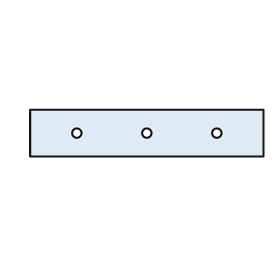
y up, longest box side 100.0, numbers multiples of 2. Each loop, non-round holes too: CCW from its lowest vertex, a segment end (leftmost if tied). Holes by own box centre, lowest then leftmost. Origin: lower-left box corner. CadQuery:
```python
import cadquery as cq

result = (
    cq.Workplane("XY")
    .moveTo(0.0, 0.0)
    .lineTo(100.0, 0.0)
    .lineTo(100.0, 20.0)
    .lineTo(0.0, 20.0)
    .close()
    .moveTo(20.0, 10.0)
    .circle(2.0)
    .moveTo(50.0, 10.0)
    .circle(2.0)
    .moveTo(80.0, 10.0)
    .circle(2.0)
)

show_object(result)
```